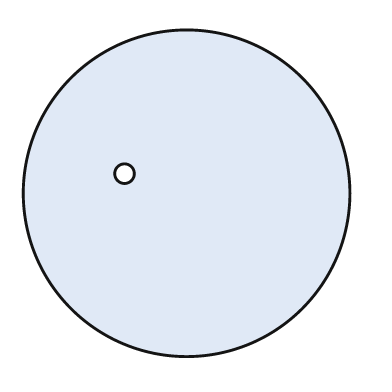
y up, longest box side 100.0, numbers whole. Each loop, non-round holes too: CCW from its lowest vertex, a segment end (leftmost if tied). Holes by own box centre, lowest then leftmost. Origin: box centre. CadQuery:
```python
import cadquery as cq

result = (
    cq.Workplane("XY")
    .moveTo(0.0, 0.0)
    .circle(50.0)
    .moveTo(-19.0, 6.0)
    .circle(3.0)
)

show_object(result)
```